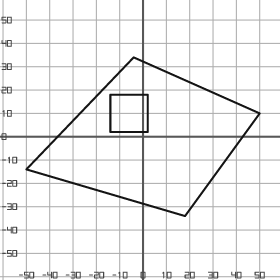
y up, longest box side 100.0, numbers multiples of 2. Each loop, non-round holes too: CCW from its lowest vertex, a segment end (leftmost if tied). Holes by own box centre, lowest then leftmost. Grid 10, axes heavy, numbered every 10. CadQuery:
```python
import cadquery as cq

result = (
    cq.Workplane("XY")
    .moveTo(18.0, -34.0)
    .lineTo(50.0, 10.0)
    .lineTo(-4.0, 34.0)
    .lineTo(-50.0, -14.0)
    .close()
    .moveTo(-14.0, 2.0)
    .lineTo(2.0, 2.0)
    .lineTo(2.0, 18.0)
    .lineTo(-14.0, 18.0)
    .close()
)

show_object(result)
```